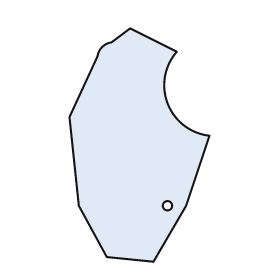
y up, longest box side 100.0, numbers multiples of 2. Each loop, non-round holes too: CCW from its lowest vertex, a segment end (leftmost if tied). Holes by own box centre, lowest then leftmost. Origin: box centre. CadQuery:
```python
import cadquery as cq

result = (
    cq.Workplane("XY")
    .moveTo(6.0, -50.0)
    .lineTo(20.0, -26.0)
    .lineTo(30.0, 4.0)
    .threePointArc((12.0, 18.0), (16.0, 40.0))
    .lineTo(-4.0, 50.0)
    .lineTo(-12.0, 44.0)
    .threePointArc((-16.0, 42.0), (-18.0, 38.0))
    .lineTo(-30.0, 12.0)
    .lineTo(-26.0, -26.0)
    .lineTo(-14.0, -48.0)
    .close()
    .moveTo(12.0, -26.0)
    .circle(2.0)
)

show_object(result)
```